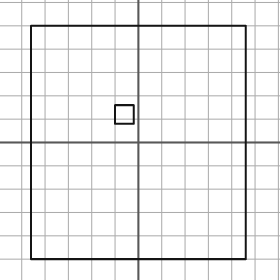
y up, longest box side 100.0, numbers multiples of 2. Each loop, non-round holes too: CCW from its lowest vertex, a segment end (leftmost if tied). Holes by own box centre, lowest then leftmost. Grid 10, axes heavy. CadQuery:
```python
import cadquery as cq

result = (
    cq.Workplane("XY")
    .moveTo(-46.0, -50.0)
    .lineTo(46.0, -50.0)
    .lineTo(46.0, 50.0)
    .lineTo(-46.0, 50.0)
    .close()
    .moveTo(-10.0, 8.0)
    .lineTo(-2.0, 8.0)
    .lineTo(-2.0, 16.0)
    .lineTo(-10.0, 16.0)
    .close()
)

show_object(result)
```